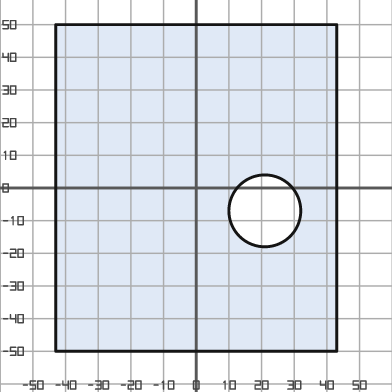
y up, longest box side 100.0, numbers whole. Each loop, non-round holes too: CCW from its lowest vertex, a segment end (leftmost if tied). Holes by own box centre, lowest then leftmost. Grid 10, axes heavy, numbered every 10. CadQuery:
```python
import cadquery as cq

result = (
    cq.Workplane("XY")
    .moveTo(-43.0, -50.0)
    .lineTo(43.0, -50.0)
    .lineTo(43.0, 50.0)
    .lineTo(-43.0, 50.0)
    .close()
    .moveTo(21.0, -7.0)
    .circle(11.0)
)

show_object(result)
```